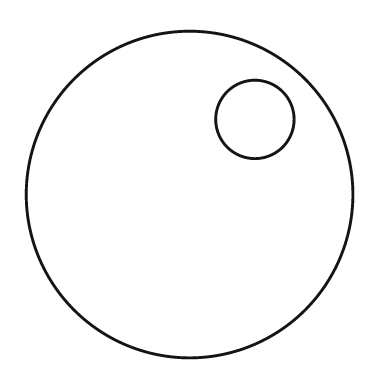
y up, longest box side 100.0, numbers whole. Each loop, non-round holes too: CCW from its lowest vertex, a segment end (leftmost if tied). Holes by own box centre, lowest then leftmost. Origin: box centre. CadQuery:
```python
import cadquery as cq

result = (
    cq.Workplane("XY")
    .moveTo(0.0, 0.0)
    .circle(50.0)
    .moveTo(20.0, 23.0)
    .circle(12.0)
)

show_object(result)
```